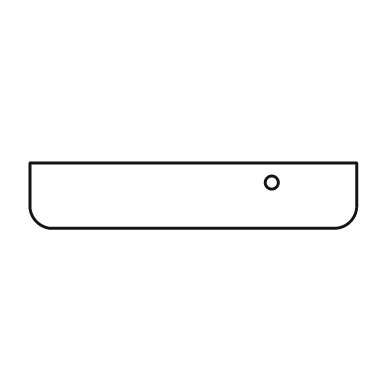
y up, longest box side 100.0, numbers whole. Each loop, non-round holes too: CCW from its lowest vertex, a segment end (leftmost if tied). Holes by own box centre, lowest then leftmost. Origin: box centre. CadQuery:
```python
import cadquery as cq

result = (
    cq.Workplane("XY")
    .moveTo(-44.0, -10.0)
    .lineTo(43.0, -10.0)
    .threePointArc((48.0, -8.0), (50.0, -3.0))
    .lineTo(50.0, 10.0)
    .lineTo(-50.0, 10.0)
    .lineTo(-50.0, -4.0)
    .threePointArc((-48.0, -8.0), (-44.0, -10.0))
    .close()
    .moveTo(24.0, 4.0)
    .circle(2.0)
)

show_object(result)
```